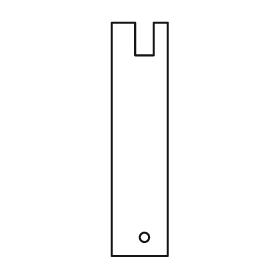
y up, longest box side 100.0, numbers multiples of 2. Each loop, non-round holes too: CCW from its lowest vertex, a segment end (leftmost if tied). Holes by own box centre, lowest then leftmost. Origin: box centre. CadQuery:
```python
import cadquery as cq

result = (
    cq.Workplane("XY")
    .moveTo(-12.0, -50.0)
    .lineTo(12.0, -50.0)
    .lineTo(12.0, 50.0)
    .lineTo(6.0, 50.0)
    .lineTo(6.0, 36.0)
    .lineTo(-2.0, 36.0)
    .lineTo(-2.0, 50.0)
    .lineTo(-12.0, 50.0)
    .close()
    .moveTo(2.0, -42.0)
    .circle(2.0)
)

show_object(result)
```